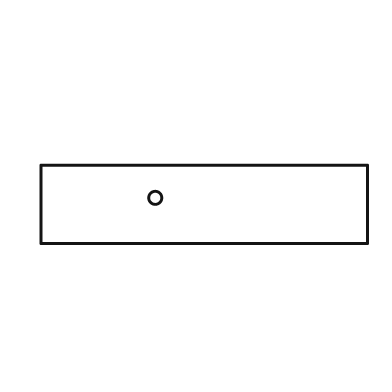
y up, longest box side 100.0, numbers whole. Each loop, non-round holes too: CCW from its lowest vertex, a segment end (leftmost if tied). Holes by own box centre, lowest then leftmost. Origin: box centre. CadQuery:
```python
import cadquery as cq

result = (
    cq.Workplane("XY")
    .moveTo(-50.0, -12.0)
    .lineTo(50.0, -12.0)
    .lineTo(50.0, 12.0)
    .lineTo(-50.0, 12.0)
    .close()
    .moveTo(-15.0, 2.0)
    .circle(2.0)
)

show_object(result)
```